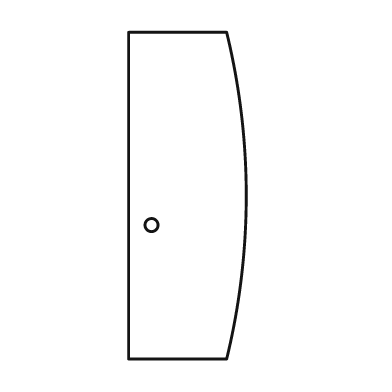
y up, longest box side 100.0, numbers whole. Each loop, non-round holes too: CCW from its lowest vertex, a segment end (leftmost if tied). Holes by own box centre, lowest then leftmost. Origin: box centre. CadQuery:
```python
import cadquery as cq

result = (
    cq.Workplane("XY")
    .moveTo(-18.0, -50.0)
    .lineTo(12.0, -50.0)
    .threePointArc((18.0, 0.0), (12.0, 50.0))
    .lineTo(-18.0, 50.0)
    .close()
    .moveTo(-11.0, -9.0)
    .circle(2.0)
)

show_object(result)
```